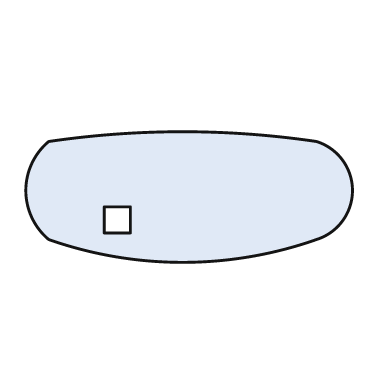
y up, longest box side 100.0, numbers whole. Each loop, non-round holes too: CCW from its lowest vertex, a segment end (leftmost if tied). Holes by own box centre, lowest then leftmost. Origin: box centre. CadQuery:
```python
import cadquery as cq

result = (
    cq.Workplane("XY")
    .moveTo(-43.0, -13.0)
    .threePointArc((-2.0, -20.0), (39.0, -13.0))
    .threePointArc((50.0, 2.0), (39.0, 17.0))
    .threePointArc((-2.0, 20.0), (-43.0, 17.0))
    .threePointArc((-50.0, 2.0), (-43.0, -13.0))
    .close()
    .moveTo(-26.0, -11.0)
    .lineTo(-18.0, -11.0)
    .lineTo(-18.0, -3.0)
    .lineTo(-26.0, -3.0)
    .close()
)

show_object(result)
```